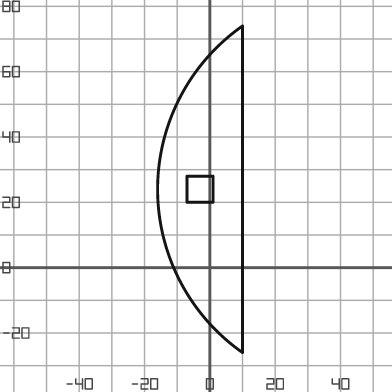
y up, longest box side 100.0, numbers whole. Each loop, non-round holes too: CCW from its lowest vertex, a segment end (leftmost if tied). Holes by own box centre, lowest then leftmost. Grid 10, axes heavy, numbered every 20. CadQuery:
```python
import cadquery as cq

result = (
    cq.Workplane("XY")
    .moveTo(10.0, -26.0)
    .lineTo(10.0, 74.0)
    .threePointArc((-16.0, 24.0), (10.0, -26.0))
    .close()
    .moveTo(-7.0, 20.0)
    .lineTo(1.0, 20.0)
    .lineTo(1.0, 28.0)
    .lineTo(-7.0, 28.0)
    .close()
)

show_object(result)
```